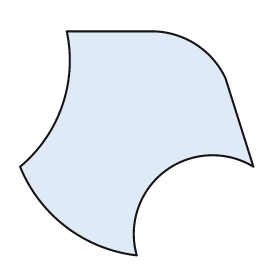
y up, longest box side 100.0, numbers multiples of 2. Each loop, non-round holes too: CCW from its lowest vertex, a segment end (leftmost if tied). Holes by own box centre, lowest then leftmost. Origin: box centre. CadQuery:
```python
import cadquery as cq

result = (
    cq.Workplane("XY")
    .moveTo(0.0, -48.0)
    .threePointArc((12.0, -12.0), (50.0, -10.0))
    .lineTo(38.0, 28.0)
    .threePointArc((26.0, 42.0), (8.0, 48.0))
    .lineTo(-30.0, 48.0)
    .threePointArc((-32.0, 16.0), (-50.0, -10.0))
    .threePointArc((-30.0, -36.0), (0.0, -48.0))
    .close()
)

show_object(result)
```